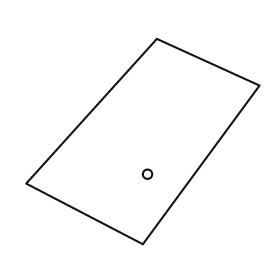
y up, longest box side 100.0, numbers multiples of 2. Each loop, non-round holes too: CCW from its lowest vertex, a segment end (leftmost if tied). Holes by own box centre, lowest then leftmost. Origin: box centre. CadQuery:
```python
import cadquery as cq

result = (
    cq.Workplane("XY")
    .moveTo(0.0, -44.0)
    .lineTo(50.0, 24.0)
    .lineTo(6.0, 44.0)
    .lineTo(-50.0, -18.0)
    .close()
    .moveTo(2.0, -14.0)
    .circle(2.0)
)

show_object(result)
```